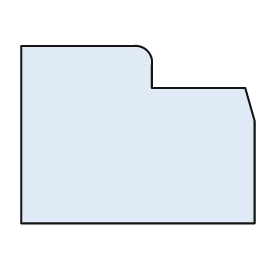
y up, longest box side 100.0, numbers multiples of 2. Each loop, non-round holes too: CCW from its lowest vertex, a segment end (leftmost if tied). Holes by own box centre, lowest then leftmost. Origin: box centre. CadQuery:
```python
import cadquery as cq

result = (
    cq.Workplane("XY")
    .moveTo(-50.0, -38.0)
    .lineTo(50.0, -38.0)
    .lineTo(50.0, 6.0)
    .lineTo(46.0, 20.0)
    .lineTo(6.0, 20.0)
    .lineTo(6.0, 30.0)
    .threePointArc((4.0, 36.0), (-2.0, 38.0))
    .lineTo(-50.0, 38.0)
    .close()
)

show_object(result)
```